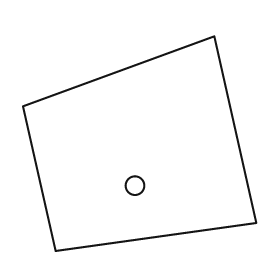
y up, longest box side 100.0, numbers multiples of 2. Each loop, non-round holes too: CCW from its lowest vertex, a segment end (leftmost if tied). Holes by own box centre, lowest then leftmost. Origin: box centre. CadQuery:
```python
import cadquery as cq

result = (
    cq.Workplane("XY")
    .moveTo(-36.0, -46.0)
    .lineTo(50.0, -34.0)
    .lineTo(32.0, 46.0)
    .lineTo(-50.0, 16.0)
    .close()
    .moveTo(-2.0, -18.0)
    .circle(4.0)
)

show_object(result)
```